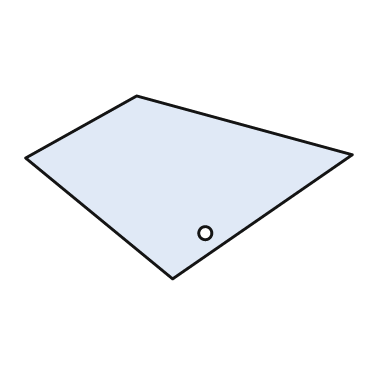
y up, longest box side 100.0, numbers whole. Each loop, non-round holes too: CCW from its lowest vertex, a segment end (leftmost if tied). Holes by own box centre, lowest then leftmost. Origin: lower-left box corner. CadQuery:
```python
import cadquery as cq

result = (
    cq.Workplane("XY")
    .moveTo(45.0, 0.0)
    .lineTo(100.0, 38.0)
    .lineTo(34.0, 56.0)
    .lineTo(0.0, 37.0)
    .close()
    .moveTo(55.0, 14.0)
    .circle(2.0)
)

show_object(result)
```